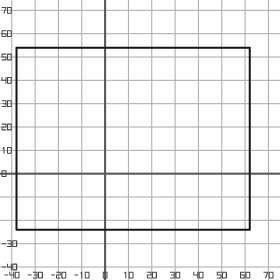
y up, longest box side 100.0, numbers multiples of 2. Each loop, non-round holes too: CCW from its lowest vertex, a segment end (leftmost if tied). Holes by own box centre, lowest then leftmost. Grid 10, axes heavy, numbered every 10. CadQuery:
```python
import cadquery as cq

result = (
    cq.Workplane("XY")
    .moveTo(-38.0, -24.0)
    .lineTo(62.0, -24.0)
    .lineTo(62.0, 54.0)
    .lineTo(-38.0, 54.0)
    .close()
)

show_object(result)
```